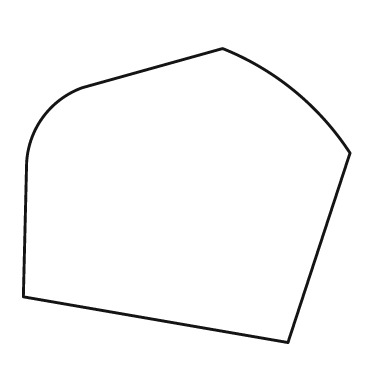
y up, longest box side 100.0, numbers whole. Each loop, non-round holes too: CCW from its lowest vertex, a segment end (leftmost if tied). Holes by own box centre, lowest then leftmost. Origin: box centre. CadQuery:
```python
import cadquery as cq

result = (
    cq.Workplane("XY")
    .moveTo(31.0, -45.0)
    .lineTo(50.0, 13.0)
    .threePointArc((33.0, 32.0), (11.0, 45.0))
    .lineTo(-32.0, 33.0)
    .threePointArc((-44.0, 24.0), (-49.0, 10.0))
    .lineTo(-50.0, -31.0)
    .close()
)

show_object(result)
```